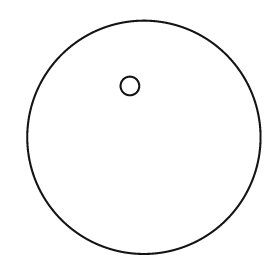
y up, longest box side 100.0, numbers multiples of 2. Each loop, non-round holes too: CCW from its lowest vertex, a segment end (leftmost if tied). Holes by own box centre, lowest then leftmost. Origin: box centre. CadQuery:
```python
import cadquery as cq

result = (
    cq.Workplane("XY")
    .moveTo(0.0, 0.0)
    .circle(50.0)
    .moveTo(-6.0, 22.0)
    .circle(4.0)
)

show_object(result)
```